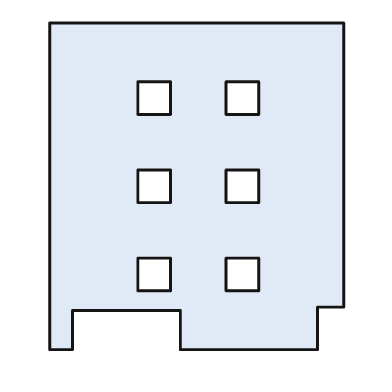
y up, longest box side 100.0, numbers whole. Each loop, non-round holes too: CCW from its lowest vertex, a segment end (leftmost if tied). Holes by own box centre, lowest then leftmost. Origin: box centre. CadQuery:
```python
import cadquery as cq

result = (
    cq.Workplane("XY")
    .moveTo(-45.0, -50.0)
    .lineTo(-38.0, -50.0)
    .lineTo(-38.0, -38.0)
    .lineTo(-5.0, -38.0)
    .lineTo(-5.0, -50.0)
    .lineTo(37.0, -50.0)
    .lineTo(37.0, -37.0)
    .lineTo(45.0, -37.0)
    .lineTo(45.0, 50.0)
    .lineTo(-45.0, 50.0)
    .close()
    .moveTo(-18.0, -32.0)
    .lineTo(-8.0, -32.0)
    .lineTo(-8.0, -22.0)
    .lineTo(-18.0, -22.0)
    .close()
    .moveTo(9.0, -32.0)
    .lineTo(19.0, -32.0)
    .lineTo(19.0, -22.0)
    .lineTo(9.0, -22.0)
    .close()
    .moveTo(-18.0, -5.0)
    .lineTo(-8.0, -5.0)
    .lineTo(-8.0, 5.0)
    .lineTo(-18.0, 5.0)
    .close()
    .moveTo(9.0, -5.0)
    .lineTo(19.0, -5.0)
    .lineTo(19.0, 5.0)
    .lineTo(9.0, 5.0)
    .close()
    .moveTo(-18.0, 22.0)
    .lineTo(-8.0, 22.0)
    .lineTo(-8.0, 32.0)
    .lineTo(-18.0, 32.0)
    .close()
    .moveTo(9.0, 22.0)
    .lineTo(19.0, 22.0)
    .lineTo(19.0, 32.0)
    .lineTo(9.0, 32.0)
    .close()
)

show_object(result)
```